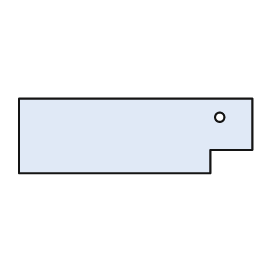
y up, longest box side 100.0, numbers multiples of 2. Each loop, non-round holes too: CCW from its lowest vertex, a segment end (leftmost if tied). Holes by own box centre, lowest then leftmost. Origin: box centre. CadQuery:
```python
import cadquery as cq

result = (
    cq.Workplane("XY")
    .moveTo(-50.0, -16.0)
    .lineTo(32.0, -16.0)
    .lineTo(32.0, -6.0)
    .lineTo(50.0, -6.0)
    .lineTo(50.0, 16.0)
    .lineTo(-50.0, 16.0)
    .close()
    .moveTo(36.0, 8.0)
    .circle(2.0)
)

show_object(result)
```